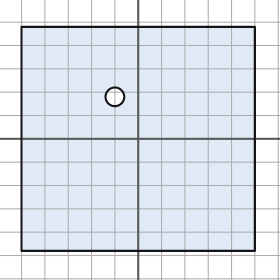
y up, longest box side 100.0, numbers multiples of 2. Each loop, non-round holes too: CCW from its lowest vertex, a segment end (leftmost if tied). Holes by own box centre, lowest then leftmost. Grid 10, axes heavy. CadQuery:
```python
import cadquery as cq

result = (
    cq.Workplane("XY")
    .moveTo(-50.0, -48.0)
    .lineTo(50.0, -48.0)
    .lineTo(50.0, 48.0)
    .lineTo(-50.0, 48.0)
    .close()
    .moveTo(-10.0, 18.0)
    .circle(4.0)
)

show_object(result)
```